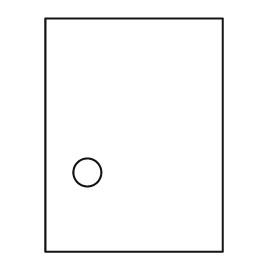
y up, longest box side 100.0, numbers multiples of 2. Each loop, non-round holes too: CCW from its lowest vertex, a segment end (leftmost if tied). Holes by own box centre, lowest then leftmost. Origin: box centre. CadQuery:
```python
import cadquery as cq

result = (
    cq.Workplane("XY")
    .moveTo(-38.0, -50.0)
    .lineTo(38.0, -50.0)
    .lineTo(38.0, 50.0)
    .lineTo(-38.0, 50.0)
    .close()
    .moveTo(-20.0, -16.0)
    .circle(6.0)
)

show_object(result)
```